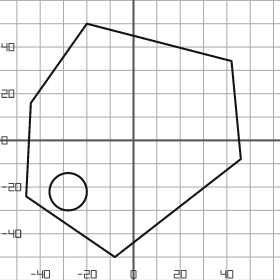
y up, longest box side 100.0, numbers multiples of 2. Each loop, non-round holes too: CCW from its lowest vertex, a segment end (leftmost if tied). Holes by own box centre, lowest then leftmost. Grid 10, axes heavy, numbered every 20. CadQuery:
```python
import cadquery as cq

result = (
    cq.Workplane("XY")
    .moveTo(-8.0, -50.0)
    .lineTo(46.0, -8.0)
    .lineTo(42.0, 34.0)
    .lineTo(-20.0, 50.0)
    .lineTo(-44.0, 16.0)
    .lineTo(-46.0, -24.0)
    .close()
    .moveTo(-28.0, -22.0)
    .circle(8.0)
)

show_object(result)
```